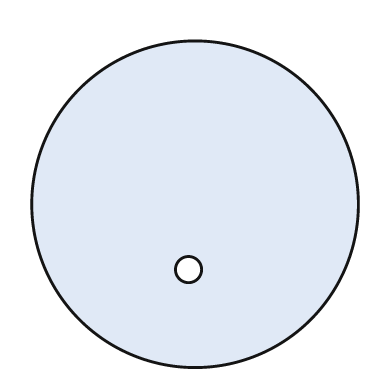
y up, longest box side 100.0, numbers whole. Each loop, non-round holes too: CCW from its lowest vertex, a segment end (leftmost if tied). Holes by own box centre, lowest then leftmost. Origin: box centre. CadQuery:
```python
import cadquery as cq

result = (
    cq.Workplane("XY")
    .moveTo(0.0, 0.0)
    .circle(50.0)
    .moveTo(-2.0, -20.0)
    .circle(4.0)
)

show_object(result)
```